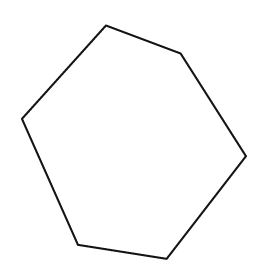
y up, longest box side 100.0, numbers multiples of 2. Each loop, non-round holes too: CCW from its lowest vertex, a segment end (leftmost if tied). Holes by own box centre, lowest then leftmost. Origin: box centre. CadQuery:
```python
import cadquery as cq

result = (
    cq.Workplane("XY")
    .moveTo(14.0, -50.0)
    .lineTo(48.0, -6.0)
    .lineTo(20.0, 38.0)
    .lineTo(-12.0, 50.0)
    .lineTo(-48.0, 10.0)
    .lineTo(-24.0, -44.0)
    .close()
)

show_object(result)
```